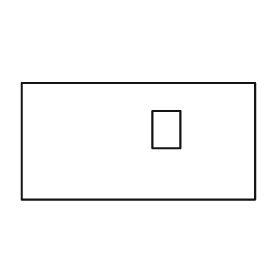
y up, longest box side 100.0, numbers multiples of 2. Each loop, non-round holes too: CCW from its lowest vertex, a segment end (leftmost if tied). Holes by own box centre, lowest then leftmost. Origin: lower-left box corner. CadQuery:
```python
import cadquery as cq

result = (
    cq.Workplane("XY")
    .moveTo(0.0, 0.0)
    .lineTo(100.0, 0.0)
    .lineTo(100.0, 50.0)
    .lineTo(0.0, 50.0)
    .close()
    .moveTo(56.0, 22.0)
    .lineTo(68.0, 22.0)
    .lineTo(68.0, 38.0)
    .lineTo(56.0, 38.0)
    .close()
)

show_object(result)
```